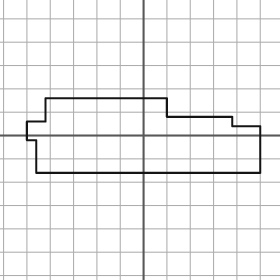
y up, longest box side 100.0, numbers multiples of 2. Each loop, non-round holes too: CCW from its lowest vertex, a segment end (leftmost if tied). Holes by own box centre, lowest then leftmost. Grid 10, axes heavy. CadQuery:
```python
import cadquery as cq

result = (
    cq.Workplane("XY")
    .moveTo(-46.0, -16.0)
    .lineTo(50.0, -16.0)
    .lineTo(50.0, 4.0)
    .lineTo(38.0, 4.0)
    .lineTo(38.0, 8.0)
    .lineTo(10.0, 8.0)
    .lineTo(10.0, 16.0)
    .lineTo(-42.0, 16.0)
    .lineTo(-42.0, 6.0)
    .lineTo(-50.0, 6.0)
    .lineTo(-50.0, -2.0)
    .lineTo(-46.0, -2.0)
    .close()
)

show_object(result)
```